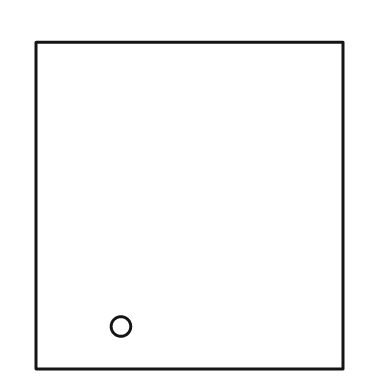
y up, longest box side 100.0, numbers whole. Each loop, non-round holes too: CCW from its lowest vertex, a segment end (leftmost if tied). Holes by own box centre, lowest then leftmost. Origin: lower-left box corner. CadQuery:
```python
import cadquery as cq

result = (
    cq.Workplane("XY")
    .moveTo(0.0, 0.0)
    .lineTo(94.0, 0.0)
    .lineTo(94.0, 100.0)
    .lineTo(0.0, 100.0)
    .close()
    .moveTo(26.0, 13.0)
    .circle(3.0)
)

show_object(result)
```